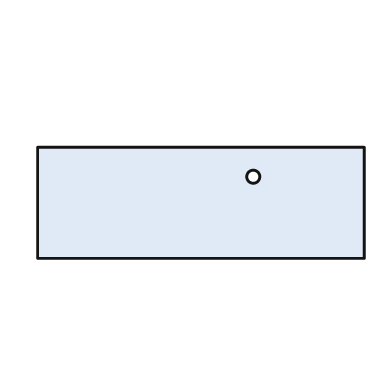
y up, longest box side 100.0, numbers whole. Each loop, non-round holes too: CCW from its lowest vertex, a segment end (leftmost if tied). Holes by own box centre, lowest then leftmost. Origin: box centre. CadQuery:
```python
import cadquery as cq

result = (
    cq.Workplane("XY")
    .moveTo(-50.0, -17.0)
    .lineTo(50.0, -17.0)
    .lineTo(50.0, 17.0)
    .lineTo(-50.0, 17.0)
    .close()
    .moveTo(16.0, 8.0)
    .circle(2.0)
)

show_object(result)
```